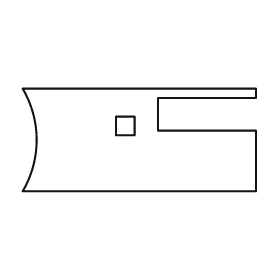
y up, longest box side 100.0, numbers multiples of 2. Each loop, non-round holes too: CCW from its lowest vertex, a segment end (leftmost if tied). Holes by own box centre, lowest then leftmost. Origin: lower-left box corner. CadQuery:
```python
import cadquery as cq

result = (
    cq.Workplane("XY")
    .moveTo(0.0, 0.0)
    .lineTo(100.0, 0.0)
    .lineTo(100.0, 26.0)
    .lineTo(58.0, 26.0)
    .lineTo(58.0, 40.0)
    .lineTo(100.0, 40.0)
    .lineTo(100.0, 44.0)
    .lineTo(0.0, 44.0)
    .threePointArc((6.0, 22.0), (0.0, 0.0))
    .close()
    .moveTo(40.0, 24.0)
    .lineTo(48.0, 24.0)
    .lineTo(48.0, 32.0)
    .lineTo(40.0, 32.0)
    .close()
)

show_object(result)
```